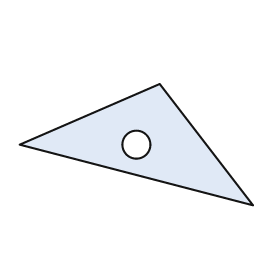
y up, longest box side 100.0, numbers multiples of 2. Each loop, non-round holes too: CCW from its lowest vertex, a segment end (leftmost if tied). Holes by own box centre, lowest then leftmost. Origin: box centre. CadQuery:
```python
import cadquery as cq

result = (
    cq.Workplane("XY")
    .moveTo(50.0, -26.0)
    .lineTo(10.0, 26.0)
    .lineTo(-50.0, 0.0)
    .close()
    .moveTo(0.0, 0.0)
    .circle(6.0)
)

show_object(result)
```